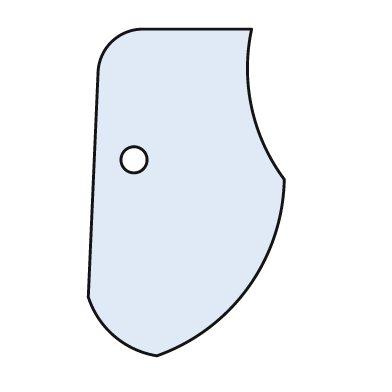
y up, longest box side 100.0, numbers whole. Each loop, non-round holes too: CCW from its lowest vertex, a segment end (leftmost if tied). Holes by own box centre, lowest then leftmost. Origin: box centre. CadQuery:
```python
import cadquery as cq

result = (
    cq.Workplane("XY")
    .moveTo(-9.0, -50.0)
    .threePointArc((19.0, -29.0), (30.0, 4.0))
    .threePointArc((20.0, 26.0), (20.0, 50.0))
    .lineTo(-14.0, 50.0)
    .threePointArc((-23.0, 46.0), (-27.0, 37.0))
    .lineTo(-30.0, -32.0)
    .threePointArc((-22.0, -44.0), (-9.0, -50.0))
    .close()
    .moveTo(-16.0, 10.0)
    .circle(4.0)
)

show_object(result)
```